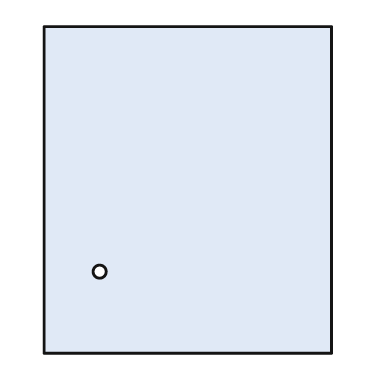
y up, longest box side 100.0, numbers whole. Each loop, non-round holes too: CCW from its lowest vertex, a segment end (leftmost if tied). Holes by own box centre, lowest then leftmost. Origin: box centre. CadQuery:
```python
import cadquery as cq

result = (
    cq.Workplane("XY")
    .moveTo(-44.0, -50.0)
    .lineTo(44.0, -50.0)
    .lineTo(44.0, 50.0)
    .lineTo(-44.0, 50.0)
    .close()
    .moveTo(-27.0, -25.0)
    .circle(2.0)
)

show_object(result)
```